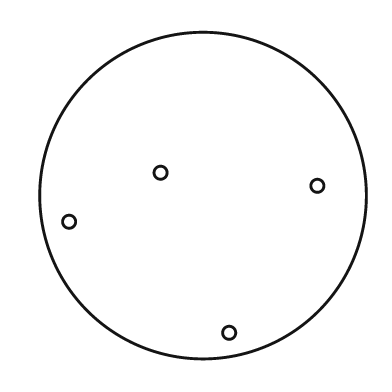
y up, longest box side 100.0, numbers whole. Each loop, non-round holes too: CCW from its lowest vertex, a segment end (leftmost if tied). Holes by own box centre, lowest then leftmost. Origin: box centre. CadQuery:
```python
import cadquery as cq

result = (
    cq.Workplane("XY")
    .moveTo(0.0, 0.0)
    .circle(50.0)
    .moveTo(8.0, -42.0)
    .circle(2.0)
    .moveTo(-41.0, -8.0)
    .circle(2.0)
    .moveTo(35.0, 3.0)
    .circle(2.0)
    .moveTo(-13.0, 7.0)
    .circle(2.0)
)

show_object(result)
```